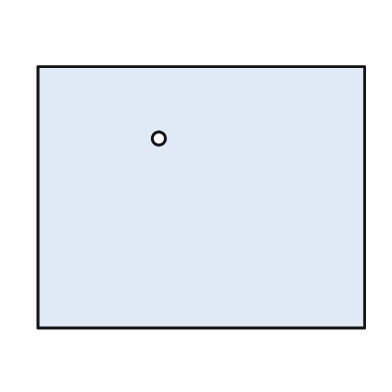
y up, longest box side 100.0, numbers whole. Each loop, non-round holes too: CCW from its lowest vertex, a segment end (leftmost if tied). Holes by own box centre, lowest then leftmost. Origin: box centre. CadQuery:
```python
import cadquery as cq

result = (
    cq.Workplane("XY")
    .moveTo(-50.0, -40.0)
    .lineTo(50.0, -40.0)
    .lineTo(50.0, 40.0)
    .lineTo(-50.0, 40.0)
    .close()
    .moveTo(-13.0, 18.0)
    .circle(2.0)
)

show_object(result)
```